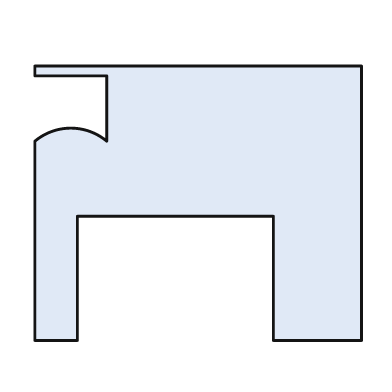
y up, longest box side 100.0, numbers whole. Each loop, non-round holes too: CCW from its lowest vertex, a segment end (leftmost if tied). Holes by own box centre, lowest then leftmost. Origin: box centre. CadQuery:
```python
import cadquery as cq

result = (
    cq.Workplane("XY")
    .moveTo(-50.0, -42.0)
    .lineTo(-37.0, -42.0)
    .lineTo(-37.0, -4.0)
    .lineTo(23.0, -4.0)
    .lineTo(23.0, -42.0)
    .lineTo(50.0, -42.0)
    .lineTo(50.0, 42.0)
    .lineTo(-50.0, 42.0)
    .lineTo(-50.0, 39.0)
    .lineTo(-28.0, 39.0)
    .lineTo(-28.0, 19.0)
    .threePointArc((-39.0, 23.0), (-50.0, 19.0))
    .close()
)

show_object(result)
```